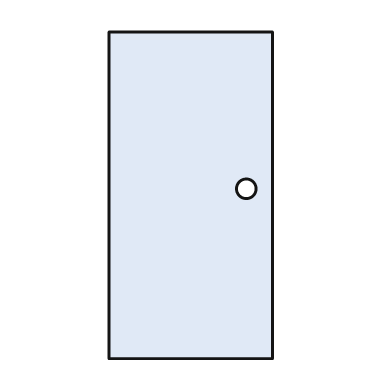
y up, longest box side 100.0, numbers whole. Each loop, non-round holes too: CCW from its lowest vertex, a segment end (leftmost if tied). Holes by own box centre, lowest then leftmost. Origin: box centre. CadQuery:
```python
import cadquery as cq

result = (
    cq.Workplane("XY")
    .moveTo(-25.0, -50.0)
    .lineTo(25.0, -50.0)
    .lineTo(25.0, 50.0)
    .lineTo(-25.0, 50.0)
    .close()
    .moveTo(17.0, 2.0)
    .circle(3.0)
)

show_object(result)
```